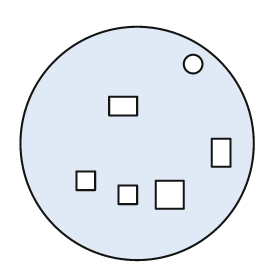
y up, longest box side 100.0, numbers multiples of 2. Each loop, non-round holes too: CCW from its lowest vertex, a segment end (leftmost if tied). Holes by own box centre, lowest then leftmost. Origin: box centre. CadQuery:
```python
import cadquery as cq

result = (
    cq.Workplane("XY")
    .moveTo(0.0, 0.0)
    .circle(50.0)
    .moveTo(-8.0, -26.0)
    .lineTo(0.0, -26.0)
    .lineTo(0.0, -18.0)
    .lineTo(-8.0, -18.0)
    .close()
    .moveTo(8.0, -28.0)
    .lineTo(20.0, -28.0)
    .lineTo(20.0, -16.0)
    .lineTo(8.0, -16.0)
    .close()
    .moveTo(-26.0, -20.0)
    .lineTo(-18.0, -20.0)
    .lineTo(-18.0, -12.0)
    .lineTo(-26.0, -12.0)
    .close()
    .moveTo(32.0, -10.0)
    .lineTo(40.0, -10.0)
    .lineTo(40.0, 2.0)
    .lineTo(32.0, 2.0)
    .close()
    .moveTo(-12.0, 12.0)
    .lineTo(0.0, 12.0)
    .lineTo(0.0, 20.0)
    .lineTo(-12.0, 20.0)
    .close()
    .moveTo(24.0, 34.0)
    .circle(4.0)
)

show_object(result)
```